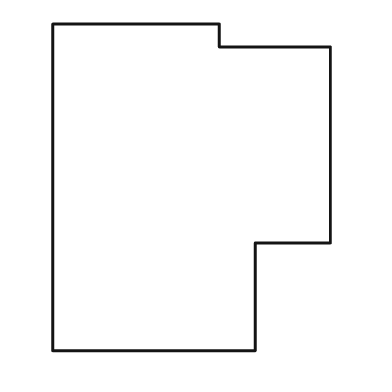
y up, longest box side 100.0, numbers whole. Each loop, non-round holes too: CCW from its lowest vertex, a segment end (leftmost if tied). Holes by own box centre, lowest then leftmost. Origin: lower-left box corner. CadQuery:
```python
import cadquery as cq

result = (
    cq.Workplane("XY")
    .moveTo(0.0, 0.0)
    .lineTo(62.0, 0.0)
    .lineTo(62.0, 33.0)
    .lineTo(85.0, 33.0)
    .lineTo(85.0, 93.0)
    .lineTo(51.0, 93.0)
    .lineTo(51.0, 100.0)
    .lineTo(0.0, 100.0)
    .close()
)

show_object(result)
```